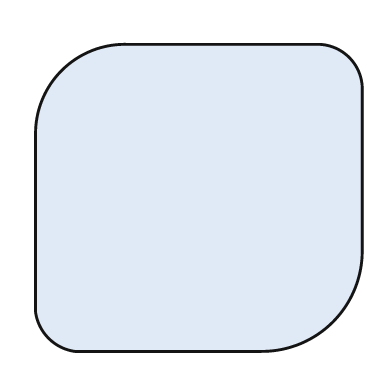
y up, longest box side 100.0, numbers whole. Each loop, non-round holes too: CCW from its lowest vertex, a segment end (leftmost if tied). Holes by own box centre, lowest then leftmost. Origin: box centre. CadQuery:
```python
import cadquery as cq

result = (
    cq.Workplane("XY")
    .moveTo(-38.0, -47.0)
    .lineTo(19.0, -47.0)
    .threePointArc((41.0, -38.0), (50.0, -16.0))
    .lineTo(50.0, 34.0)
    .threePointArc((46.0, 43.0), (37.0, 47.0))
    .lineTo(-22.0, 47.0)
    .threePointArc((-42.0, 39.0), (-50.0, 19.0))
    .lineTo(-50.0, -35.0)
    .threePointArc((-46.0, -43.0), (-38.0, -47.0))
    .close()
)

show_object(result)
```